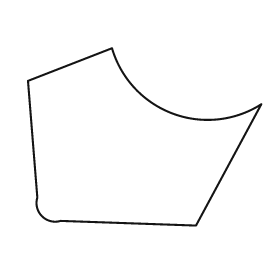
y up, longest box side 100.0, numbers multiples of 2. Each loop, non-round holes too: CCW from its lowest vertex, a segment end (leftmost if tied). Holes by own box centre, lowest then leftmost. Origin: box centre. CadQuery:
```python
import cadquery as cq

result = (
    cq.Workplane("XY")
    .moveTo(22.0, -38.0)
    .lineTo(50.0, 14.0)
    .threePointArc((12.0, 10.0), (-14.0, 38.0))
    .lineTo(-50.0, 24.0)
    .lineTo(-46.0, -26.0)
    .threePointArc((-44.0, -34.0), (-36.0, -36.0))
    .close()
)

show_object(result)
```